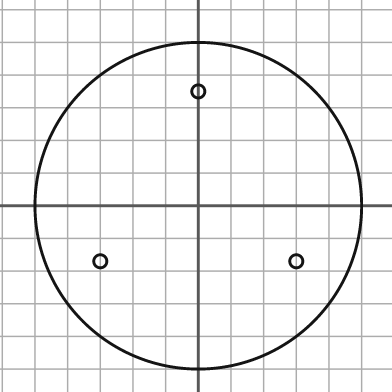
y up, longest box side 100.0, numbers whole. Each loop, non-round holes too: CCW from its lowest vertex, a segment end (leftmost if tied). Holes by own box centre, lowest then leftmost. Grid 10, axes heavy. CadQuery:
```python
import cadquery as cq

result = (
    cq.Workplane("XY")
    .moveTo(0.0, 0.0)
    .circle(50.0)
    .moveTo(-30.0, -17.0)
    .circle(2.0)
    .moveTo(30.0, -17.0)
    .circle(2.0)
    .moveTo(0.0, 35.0)
    .circle(2.0)
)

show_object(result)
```